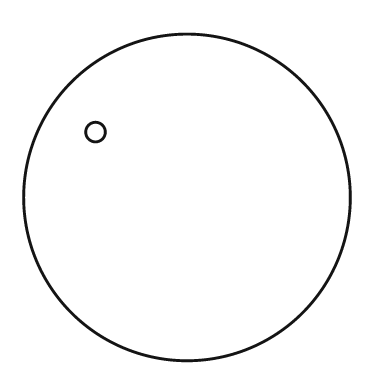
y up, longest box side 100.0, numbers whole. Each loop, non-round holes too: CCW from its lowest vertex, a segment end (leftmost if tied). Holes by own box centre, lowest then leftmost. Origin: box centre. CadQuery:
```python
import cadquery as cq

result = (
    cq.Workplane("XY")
    .moveTo(0.0, 0.0)
    .circle(50.0)
    .moveTo(-28.0, 20.0)
    .circle(3.0)
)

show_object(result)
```